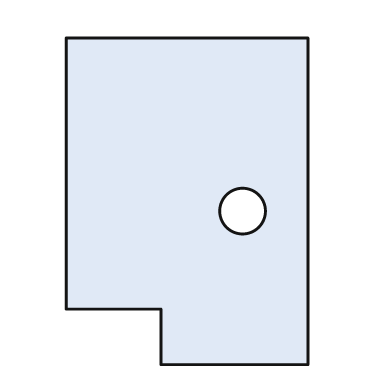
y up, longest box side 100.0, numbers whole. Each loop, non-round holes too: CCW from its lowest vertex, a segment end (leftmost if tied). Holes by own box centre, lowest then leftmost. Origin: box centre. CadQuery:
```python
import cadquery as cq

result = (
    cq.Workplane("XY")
    .moveTo(-8.0, -50.0)
    .lineTo(37.0, -50.0)
    .lineTo(37.0, 50.0)
    .lineTo(-37.0, 50.0)
    .lineTo(-37.0, -33.0)
    .lineTo(-8.0, -33.0)
    .close()
    .moveTo(17.0, -3.0)
    .circle(7.0)
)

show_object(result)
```